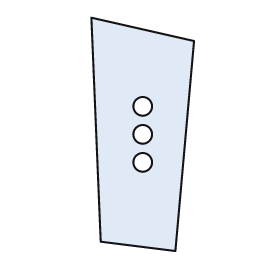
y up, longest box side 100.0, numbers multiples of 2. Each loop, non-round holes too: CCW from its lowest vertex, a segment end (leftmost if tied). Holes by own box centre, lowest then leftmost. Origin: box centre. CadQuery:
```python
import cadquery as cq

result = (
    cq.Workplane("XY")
    .moveTo(14.0, -50.0)
    .lineTo(22.0, 40.0)
    .lineTo(-22.0, 50.0)
    .lineTo(-18.0, -46.0)
    .close()
    .moveTo(0.0, -12.0)
    .circle(4.0)
    .moveTo(0.0, 0.0)
    .circle(4.0)
    .moveTo(0.0, 12.0)
    .circle(4.0)
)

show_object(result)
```